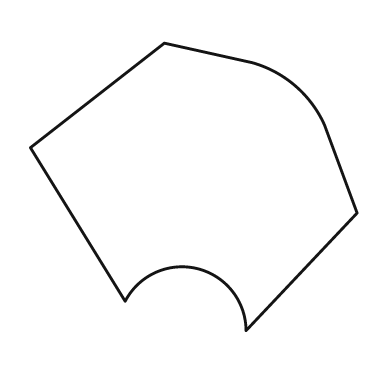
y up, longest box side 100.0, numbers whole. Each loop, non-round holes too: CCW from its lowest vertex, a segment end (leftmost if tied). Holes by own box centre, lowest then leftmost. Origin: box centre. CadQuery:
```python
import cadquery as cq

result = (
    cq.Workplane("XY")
    .moveTo(16.0, -44.0)
    .lineTo(50.0, -8.0)
    .lineTo(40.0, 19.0)
    .threePointArc((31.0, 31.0), (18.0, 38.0))
    .lineTo(-9.0, 44.0)
    .lineTo(-50.0, 12.0)
    .lineTo(-21.0, -35.0)
    .threePointArc((1.0, -25.0), (16.0, -44.0))
    .close()
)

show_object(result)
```